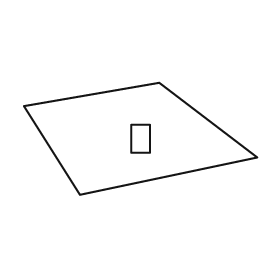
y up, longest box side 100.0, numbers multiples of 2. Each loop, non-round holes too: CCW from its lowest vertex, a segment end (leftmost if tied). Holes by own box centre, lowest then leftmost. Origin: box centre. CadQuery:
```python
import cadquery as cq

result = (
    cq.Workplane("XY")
    .moveTo(-26.0, -24.0)
    .lineTo(50.0, -8.0)
    .lineTo(8.0, 24.0)
    .lineTo(-50.0, 14.0)
    .close()
    .moveTo(-4.0, -6.0)
    .lineTo(4.0, -6.0)
    .lineTo(4.0, 6.0)
    .lineTo(-4.0, 6.0)
    .close()
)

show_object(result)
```